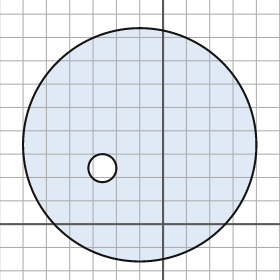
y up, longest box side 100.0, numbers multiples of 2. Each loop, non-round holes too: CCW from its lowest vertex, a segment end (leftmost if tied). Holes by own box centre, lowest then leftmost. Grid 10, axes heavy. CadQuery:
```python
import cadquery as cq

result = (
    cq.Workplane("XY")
    .moveTo(-10.0, 34.0)
    .circle(50.0)
    .moveTo(-26.0, 24.0)
    .circle(6.0)
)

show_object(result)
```